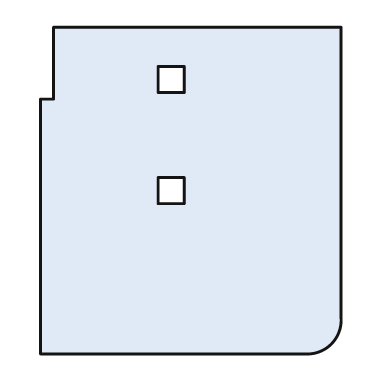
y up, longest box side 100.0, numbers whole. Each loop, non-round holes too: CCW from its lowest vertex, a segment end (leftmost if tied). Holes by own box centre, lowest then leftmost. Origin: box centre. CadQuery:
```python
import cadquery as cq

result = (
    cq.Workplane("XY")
    .moveTo(-46.0, -50.0)
    .lineTo(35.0, -50.0)
    .threePointArc((43.0, -47.0), (46.0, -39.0))
    .lineTo(46.0, 50.0)
    .lineTo(-42.0, 50.0)
    .lineTo(-42.0, 28.0)
    .lineTo(-46.0, 28.0)
    .close()
    .moveTo(-10.0, -4.0)
    .lineTo(-2.0, -4.0)
    .lineTo(-2.0, 4.0)
    .lineTo(-10.0, 4.0)
    .close()
    .moveTo(-10.0, 30.0)
    .lineTo(-2.0, 30.0)
    .lineTo(-2.0, 38.0)
    .lineTo(-10.0, 38.0)
    .close()
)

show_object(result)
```